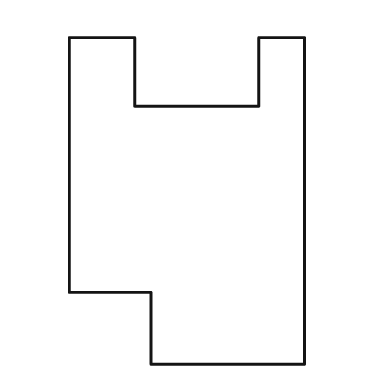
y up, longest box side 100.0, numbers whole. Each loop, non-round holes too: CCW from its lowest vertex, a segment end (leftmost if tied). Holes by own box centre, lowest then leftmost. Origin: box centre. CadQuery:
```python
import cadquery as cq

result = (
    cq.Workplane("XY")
    .moveTo(-11.0, -50.0)
    .lineTo(36.0, -50.0)
    .lineTo(36.0, 50.0)
    .lineTo(22.0, 50.0)
    .lineTo(22.0, 29.0)
    .lineTo(-16.0, 29.0)
    .lineTo(-16.0, 50.0)
    .lineTo(-36.0, 50.0)
    .lineTo(-36.0, -28.0)
    .lineTo(-11.0, -28.0)
    .close()
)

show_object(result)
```